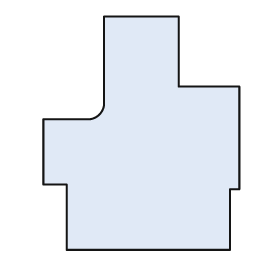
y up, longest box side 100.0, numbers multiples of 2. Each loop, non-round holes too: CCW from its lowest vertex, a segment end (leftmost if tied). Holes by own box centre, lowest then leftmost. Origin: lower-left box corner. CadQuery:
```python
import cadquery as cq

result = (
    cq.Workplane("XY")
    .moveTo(10.0, 0.0)
    .lineTo(80.0, 0.0)
    .lineTo(80.0, 26.0)
    .lineTo(84.0, 26.0)
    .lineTo(84.0, 70.0)
    .lineTo(58.0, 70.0)
    .lineTo(58.0, 100.0)
    .lineTo(26.0, 100.0)
    .lineTo(26.0, 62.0)
    .threePointArc((24.0, 58.0), (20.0, 56.0))
    .lineTo(0.0, 56.0)
    .lineTo(0.0, 28.0)
    .lineTo(10.0, 28.0)
    .close()
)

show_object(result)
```